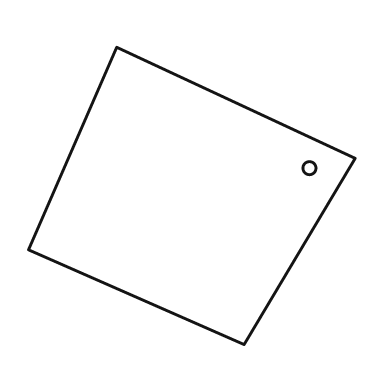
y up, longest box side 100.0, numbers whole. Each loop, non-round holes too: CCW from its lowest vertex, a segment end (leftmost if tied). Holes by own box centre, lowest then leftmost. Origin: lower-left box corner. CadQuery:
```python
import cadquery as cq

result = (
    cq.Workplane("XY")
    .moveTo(66.0, 0.0)
    .lineTo(100.0, 57.0)
    .lineTo(27.0, 91.0)
    .lineTo(0.0, 29.0)
    .close()
    .moveTo(86.0, 54.0)
    .circle(2.0)
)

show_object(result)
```